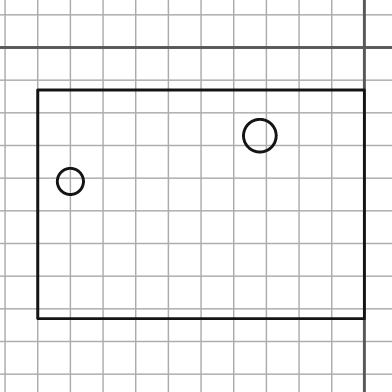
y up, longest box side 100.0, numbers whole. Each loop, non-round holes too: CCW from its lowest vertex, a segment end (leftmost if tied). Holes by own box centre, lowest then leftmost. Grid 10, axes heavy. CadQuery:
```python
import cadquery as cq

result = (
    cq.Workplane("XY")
    .moveTo(-100.0, -83.0)
    .lineTo(0.0, -83.0)
    .lineTo(0.0, -13.0)
    .lineTo(-100.0, -13.0)
    .close()
    .moveTo(-90.0, -41.0)
    .circle(4.0)
    .moveTo(-32.0, -27.0)
    .circle(5.0)
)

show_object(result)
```